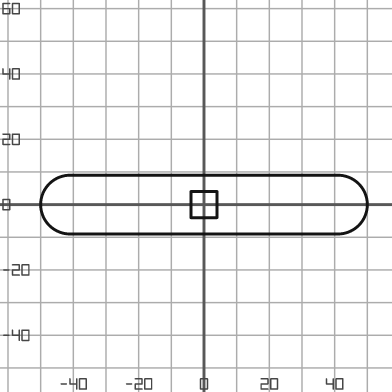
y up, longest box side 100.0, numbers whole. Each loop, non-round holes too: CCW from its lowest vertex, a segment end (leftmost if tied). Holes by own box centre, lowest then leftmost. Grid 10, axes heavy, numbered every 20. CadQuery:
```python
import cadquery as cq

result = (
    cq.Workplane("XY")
    .moveTo(-41.0, -9.0)
    .lineTo(41.0, -9.0)
    .threePointArc((50.0, 0.0), (41.0, 9.0))
    .lineTo(-41.0, 9.0)
    .threePointArc((-50.0, 0.0), (-41.0, -9.0))
    .close()
    .moveTo(-4.0, -4.0)
    .lineTo(4.0, -4.0)
    .lineTo(4.0, 4.0)
    .lineTo(-4.0, 4.0)
    .close()
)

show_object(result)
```